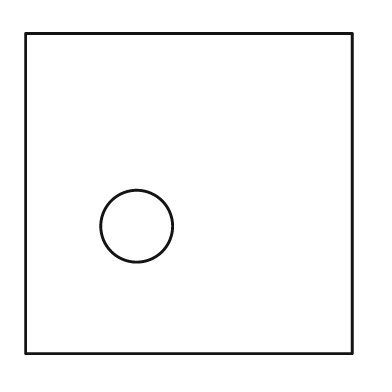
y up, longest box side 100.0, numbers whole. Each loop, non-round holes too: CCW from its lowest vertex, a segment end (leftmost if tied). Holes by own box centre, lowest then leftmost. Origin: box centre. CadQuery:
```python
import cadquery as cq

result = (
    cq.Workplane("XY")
    .moveTo(-50.0, -49.0)
    .lineTo(50.0, -49.0)
    .lineTo(50.0, 49.0)
    .lineTo(-50.0, 49.0)
    .close()
    .moveTo(-16.0, -10.0)
    .circle(11.0)
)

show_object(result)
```